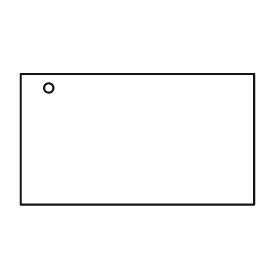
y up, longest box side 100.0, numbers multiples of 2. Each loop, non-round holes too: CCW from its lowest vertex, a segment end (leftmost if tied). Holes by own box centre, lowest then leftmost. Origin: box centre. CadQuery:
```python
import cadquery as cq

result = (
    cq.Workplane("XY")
    .moveTo(-50.0, -28.0)
    .lineTo(50.0, -28.0)
    .lineTo(50.0, 28.0)
    .lineTo(-50.0, 28.0)
    .close()
    .moveTo(-38.0, 22.0)
    .circle(2.0)
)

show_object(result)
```